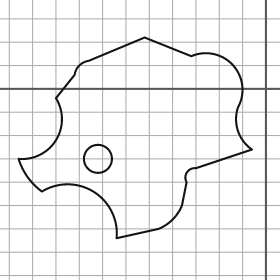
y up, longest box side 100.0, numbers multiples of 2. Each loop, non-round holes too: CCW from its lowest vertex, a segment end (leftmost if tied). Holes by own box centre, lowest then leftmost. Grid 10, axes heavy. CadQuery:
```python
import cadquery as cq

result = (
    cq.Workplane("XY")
    .moveTo(-64.0, -64.0)
    .lineTo(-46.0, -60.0)
    .threePointArc((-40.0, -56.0), (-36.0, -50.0))
    .lineTo(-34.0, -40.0)
    .threePointArc((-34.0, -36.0), (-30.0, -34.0))
    .lineTo(-6.0, -26.0)
    .threePointArc((-12.0, -18.0), (-12.0, -8.0))
    .threePointArc((-14.0, 10.0), (-32.0, 14.0))
    .lineTo(-52.0, 22.0)
    .lineTo(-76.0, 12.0)
    .threePointArc((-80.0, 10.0), (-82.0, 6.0))
    .lineTo(-90.0, -4.0)
    .threePointArc((-90.0, -22.0), (-106.0, -30.0))
    .threePointArc((-102.0, -38.0), (-96.0, -44.0))
    .threePointArc((-74.0, -44.0), (-64.0, -64.0))
    .close()
    .moveTo(-72.0, -30.0)
    .circle(6.0)
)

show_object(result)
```